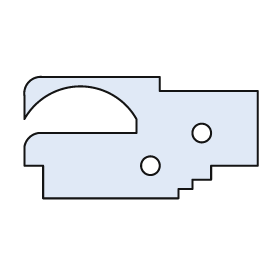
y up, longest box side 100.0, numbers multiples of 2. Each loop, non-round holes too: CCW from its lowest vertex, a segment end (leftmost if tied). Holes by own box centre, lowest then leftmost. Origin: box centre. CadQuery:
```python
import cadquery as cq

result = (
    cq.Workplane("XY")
    .moveTo(-42.0, -26.0)
    .lineTo(16.0, -26.0)
    .lineTo(16.0, -22.0)
    .lineTo(22.0, -22.0)
    .lineTo(22.0, -18.0)
    .lineTo(30.0, -18.0)
    .lineTo(30.0, -12.0)
    .lineTo(50.0, -12.0)
    .lineTo(50.0, 20.0)
    .lineTo(8.0, 20.0)
    .lineTo(8.0, 26.0)
    .lineTo(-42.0, 26.0)
    .threePointArc((-48.0, 24.0), (-50.0, 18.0))
    .lineTo(-50.0, 8.0)
    .threePointArc((-26.0, 22.0), (-2.0, 8.0))
    .lineTo(-2.0, 2.0)
    .lineTo(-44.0, 2.0)
    .threePointArc((-48.0, 0.0), (-50.0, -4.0))
    .lineTo(-50.0, -12.0)
    .lineTo(-42.0, -12.0)
    .close()
    .moveTo(4.0, -12.0)
    .circle(4.0)
    .moveTo(26.0, 2.0)
    .circle(4.0)
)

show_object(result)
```